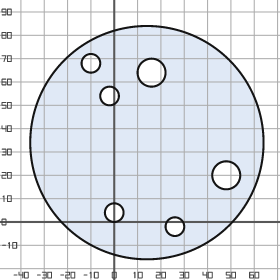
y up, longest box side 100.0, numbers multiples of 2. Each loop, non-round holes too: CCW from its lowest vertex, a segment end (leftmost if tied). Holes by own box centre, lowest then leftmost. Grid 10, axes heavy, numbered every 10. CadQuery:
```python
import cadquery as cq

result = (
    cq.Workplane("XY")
    .moveTo(14.0, 34.0)
    .circle(50.0)
    .moveTo(26.0, -2.0)
    .circle(4.0)
    .moveTo(0.0, 4.0)
    .circle(4.0)
    .moveTo(48.0, 20.0)
    .circle(6.0)
    .moveTo(-2.0, 54.0)
    .circle(4.0)
    .moveTo(16.0, 64.0)
    .circle(6.0)
    .moveTo(-10.0, 68.0)
    .circle(4.0)
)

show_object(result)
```